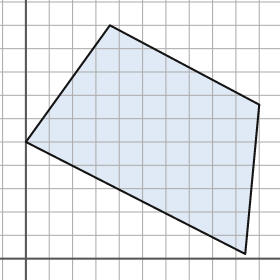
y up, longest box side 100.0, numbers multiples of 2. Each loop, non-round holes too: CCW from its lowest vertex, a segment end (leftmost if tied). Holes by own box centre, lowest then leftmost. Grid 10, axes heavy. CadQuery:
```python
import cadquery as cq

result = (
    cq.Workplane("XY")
    .moveTo(94.0, 2.0)
    .lineTo(100.0, 66.0)
    .lineTo(36.0, 100.0)
    .lineTo(0.0, 50.0)
    .close()
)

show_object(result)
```